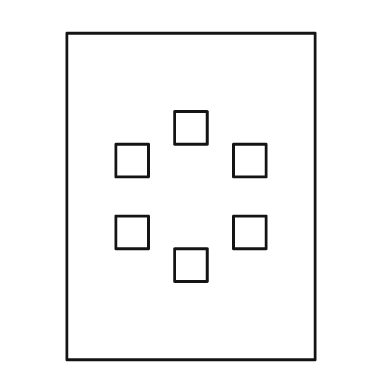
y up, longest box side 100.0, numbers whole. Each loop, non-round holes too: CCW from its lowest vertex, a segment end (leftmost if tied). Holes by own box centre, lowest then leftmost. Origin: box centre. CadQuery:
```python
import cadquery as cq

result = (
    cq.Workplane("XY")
    .moveTo(-38.0, -50.0)
    .lineTo(38.0, -50.0)
    .lineTo(38.0, 50.0)
    .lineTo(-38.0, 50.0)
    .close()
    .moveTo(-5.0, -26.0)
    .lineTo(5.0, -26.0)
    .lineTo(5.0, -16.0)
    .lineTo(-5.0, -16.0)
    .close()
    .moveTo(-23.0, -16.0)
    .lineTo(-13.0, -16.0)
    .lineTo(-13.0, -6.0)
    .lineTo(-23.0, -6.0)
    .close()
    .moveTo(13.0, -16.0)
    .lineTo(23.0, -16.0)
    .lineTo(23.0, -6.0)
    .lineTo(13.0, -6.0)
    .close()
    .moveTo(-23.0, 6.0)
    .lineTo(-13.0, 6.0)
    .lineTo(-13.0, 16.0)
    .lineTo(-23.0, 16.0)
    .close()
    .moveTo(13.0, 6.0)
    .lineTo(23.0, 6.0)
    .lineTo(23.0, 16.0)
    .lineTo(13.0, 16.0)
    .close()
    .moveTo(-5.0, 16.0)
    .lineTo(5.0, 16.0)
    .lineTo(5.0, 26.0)
    .lineTo(-5.0, 26.0)
    .close()
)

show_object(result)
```